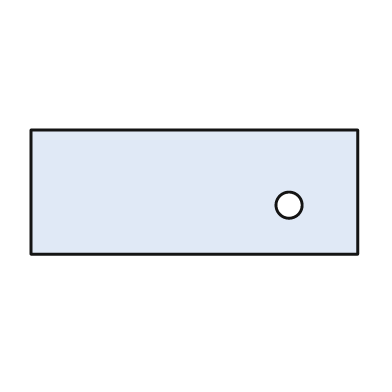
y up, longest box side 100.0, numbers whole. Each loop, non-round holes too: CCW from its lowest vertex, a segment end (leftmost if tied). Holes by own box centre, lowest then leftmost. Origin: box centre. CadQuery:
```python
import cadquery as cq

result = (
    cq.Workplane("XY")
    .moveTo(-50.0, -19.0)
    .lineTo(50.0, -19.0)
    .lineTo(50.0, 19.0)
    .lineTo(-50.0, 19.0)
    .close()
    .moveTo(29.0, -4.0)
    .circle(4.0)
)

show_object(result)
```